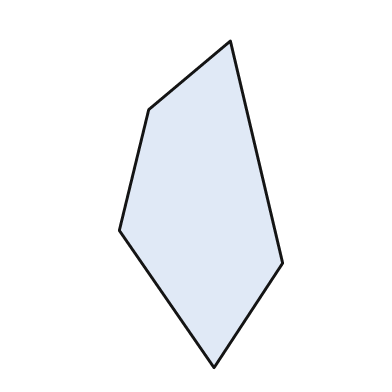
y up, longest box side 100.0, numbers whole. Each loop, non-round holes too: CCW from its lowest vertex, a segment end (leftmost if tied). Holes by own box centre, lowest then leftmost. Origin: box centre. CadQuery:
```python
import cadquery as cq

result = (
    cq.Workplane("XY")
    .moveTo(4.0, -50.0)
    .lineTo(25.0, -18.0)
    .lineTo(9.0, 50.0)
    .lineTo(-16.0, 29.0)
    .lineTo(-25.0, -8.0)
    .close()
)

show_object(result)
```